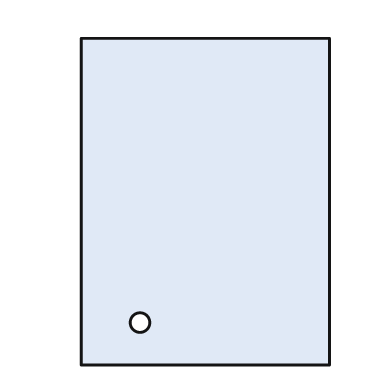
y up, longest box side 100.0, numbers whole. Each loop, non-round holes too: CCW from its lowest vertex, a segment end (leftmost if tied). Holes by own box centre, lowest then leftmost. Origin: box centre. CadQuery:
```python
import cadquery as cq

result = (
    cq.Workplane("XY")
    .moveTo(-38.0, -50.0)
    .lineTo(38.0, -50.0)
    .lineTo(38.0, 50.0)
    .lineTo(-38.0, 50.0)
    .close()
    .moveTo(-20.0, -37.0)
    .circle(3.0)
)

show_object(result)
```